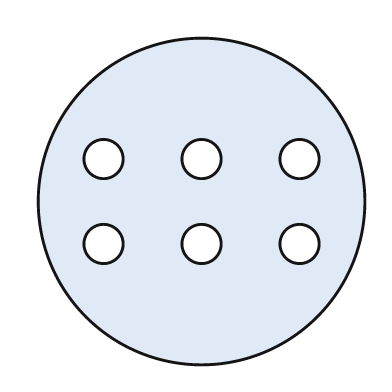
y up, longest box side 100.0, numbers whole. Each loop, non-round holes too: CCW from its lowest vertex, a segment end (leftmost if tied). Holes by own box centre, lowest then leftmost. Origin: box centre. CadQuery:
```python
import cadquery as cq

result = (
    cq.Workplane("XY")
    .moveTo(0.0, 0.0)
    .circle(50.0)
    .moveTo(-30.0, -13.0)
    .circle(6.0)
    .moveTo(0.0, -13.0)
    .circle(6.0)
    .moveTo(30.0, -13.0)
    .circle(6.0)
    .moveTo(-30.0, 13.0)
    .circle(6.0)
    .moveTo(0.0, 13.0)
    .circle(6.0)
    .moveTo(30.0, 13.0)
    .circle(6.0)
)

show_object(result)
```